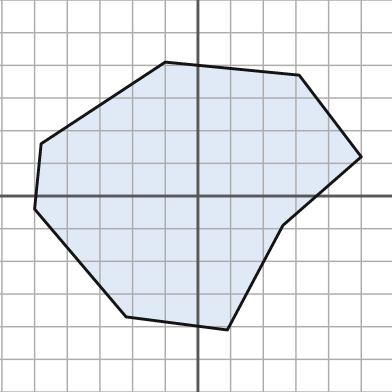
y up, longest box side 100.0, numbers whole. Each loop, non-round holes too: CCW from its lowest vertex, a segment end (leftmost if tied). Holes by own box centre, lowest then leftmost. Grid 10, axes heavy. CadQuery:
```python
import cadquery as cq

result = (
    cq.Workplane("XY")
    .moveTo(9.0, -41.0)
    .lineTo(26.0, -9.0)
    .lineTo(50.0, 12.0)
    .lineTo(31.0, 37.0)
    .lineTo(-10.0, 41.0)
    .lineTo(-48.0, 16.0)
    .lineTo(-50.0, -4.0)
    .lineTo(-22.0, -37.0)
    .close()
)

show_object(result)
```